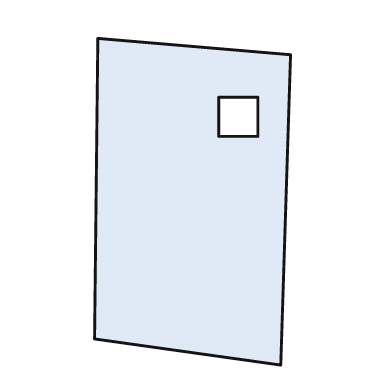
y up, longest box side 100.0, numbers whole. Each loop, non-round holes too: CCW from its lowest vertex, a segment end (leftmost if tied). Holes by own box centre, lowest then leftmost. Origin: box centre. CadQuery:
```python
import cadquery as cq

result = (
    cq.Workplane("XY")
    .moveTo(27.0, -50.0)
    .lineTo(30.0, 45.0)
    .lineTo(-29.0, 50.0)
    .lineTo(-30.0, -42.0)
    .close()
    .moveTo(8.0, 20.0)
    .lineTo(20.0, 20.0)
    .lineTo(20.0, 32.0)
    .lineTo(8.0, 32.0)
    .close()
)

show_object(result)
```